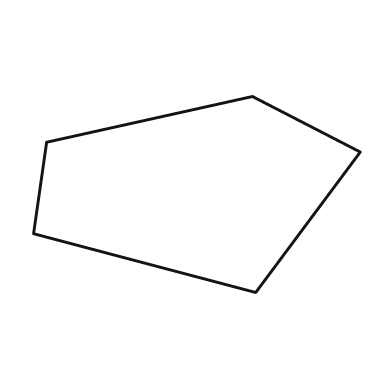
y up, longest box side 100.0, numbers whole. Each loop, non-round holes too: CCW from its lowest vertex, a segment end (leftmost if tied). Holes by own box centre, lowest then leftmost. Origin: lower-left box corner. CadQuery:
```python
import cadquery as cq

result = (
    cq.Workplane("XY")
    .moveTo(68.0, 0.0)
    .lineTo(100.0, 43.0)
    .lineTo(67.0, 60.0)
    .lineTo(4.0, 46.0)
    .lineTo(0.0, 18.0)
    .close()
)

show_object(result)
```